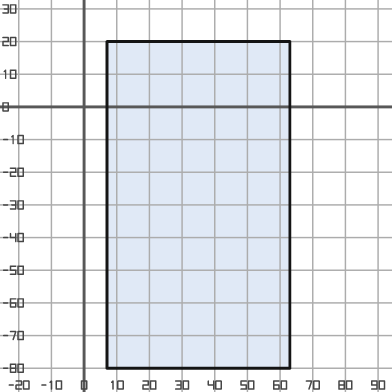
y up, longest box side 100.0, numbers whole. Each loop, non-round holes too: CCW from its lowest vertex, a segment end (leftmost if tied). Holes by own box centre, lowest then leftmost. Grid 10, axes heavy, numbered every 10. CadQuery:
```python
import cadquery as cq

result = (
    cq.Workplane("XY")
    .moveTo(7.0, -80.0)
    .lineTo(63.0, -80.0)
    .lineTo(63.0, 20.0)
    .lineTo(7.0, 20.0)
    .close()
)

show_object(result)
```